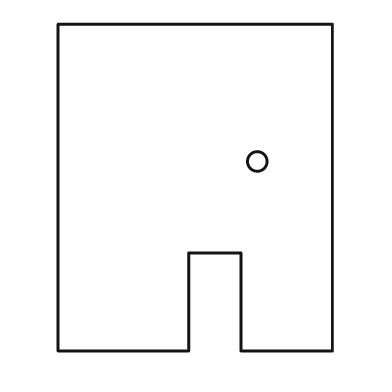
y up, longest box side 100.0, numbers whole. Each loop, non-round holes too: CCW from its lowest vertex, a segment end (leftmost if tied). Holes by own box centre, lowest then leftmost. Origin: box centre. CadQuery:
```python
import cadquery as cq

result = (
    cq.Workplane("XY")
    .moveTo(-42.0, -50.0)
    .lineTo(-2.0, -50.0)
    .lineTo(-2.0, -20.0)
    .lineTo(14.0, -20.0)
    .lineTo(14.0, -50.0)
    .lineTo(42.0, -50.0)
    .lineTo(42.0, 50.0)
    .lineTo(-42.0, 50.0)
    .close()
    .moveTo(19.0, 8.0)
    .circle(3.0)
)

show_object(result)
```